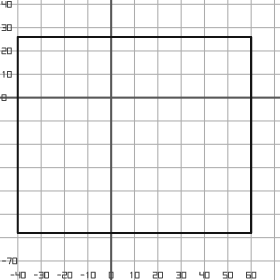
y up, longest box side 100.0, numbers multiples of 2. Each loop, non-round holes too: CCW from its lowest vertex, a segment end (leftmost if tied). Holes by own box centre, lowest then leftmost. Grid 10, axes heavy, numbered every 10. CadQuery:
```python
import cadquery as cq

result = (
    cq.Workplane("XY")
    .moveTo(-40.0, -58.0)
    .lineTo(60.0, -58.0)
    .lineTo(60.0, 26.0)
    .lineTo(-40.0, 26.0)
    .close()
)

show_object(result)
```